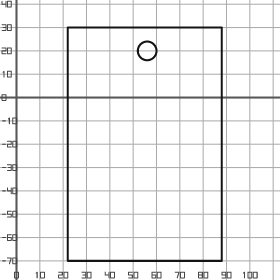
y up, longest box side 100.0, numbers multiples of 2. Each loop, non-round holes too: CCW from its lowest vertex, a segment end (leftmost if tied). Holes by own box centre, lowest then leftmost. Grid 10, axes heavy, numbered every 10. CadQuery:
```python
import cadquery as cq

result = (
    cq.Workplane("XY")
    .moveTo(22.0, -70.0)
    .lineTo(88.0, -70.0)
    .lineTo(88.0, 30.0)
    .lineTo(22.0, 30.0)
    .close()
    .moveTo(56.0, 20.0)
    .circle(4.0)
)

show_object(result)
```